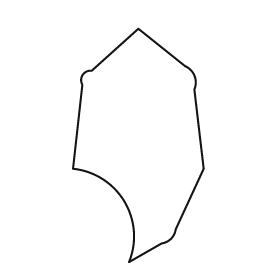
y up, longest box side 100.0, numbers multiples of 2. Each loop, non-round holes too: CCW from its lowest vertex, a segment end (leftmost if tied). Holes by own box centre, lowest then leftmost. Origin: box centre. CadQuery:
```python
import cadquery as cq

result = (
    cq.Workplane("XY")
    .moveTo(-4.0, -50.0)
    .lineTo(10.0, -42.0)
    .threePointArc((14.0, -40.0), (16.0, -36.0))
    .lineTo(28.0, -10.0)
    .lineTo(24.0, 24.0)
    .threePointArc((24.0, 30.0), (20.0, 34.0))
    .lineTo(0.0, 50.0)
    .lineTo(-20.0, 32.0)
    .threePointArc((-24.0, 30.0), (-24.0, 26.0))
    .lineTo(-28.0, -10.0)
    .threePointArc((-6.0, -24.0), (-4.0, -50.0))
    .close()
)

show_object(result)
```